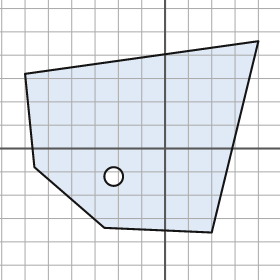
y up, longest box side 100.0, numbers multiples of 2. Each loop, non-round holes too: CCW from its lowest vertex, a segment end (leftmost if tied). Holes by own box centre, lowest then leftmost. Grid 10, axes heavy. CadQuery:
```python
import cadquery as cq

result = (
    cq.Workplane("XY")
    .moveTo(20.0, -36.0)
    .lineTo(40.0, 46.0)
    .lineTo(-60.0, 32.0)
    .lineTo(-56.0, -8.0)
    .lineTo(-26.0, -34.0)
    .close()
    .moveTo(-22.0, -12.0)
    .circle(4.0)
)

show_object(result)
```